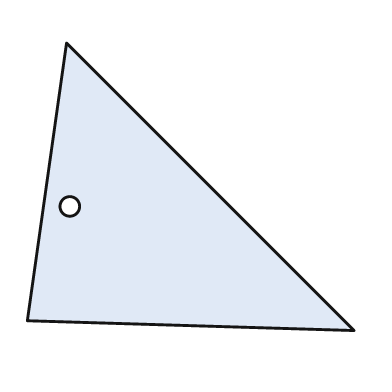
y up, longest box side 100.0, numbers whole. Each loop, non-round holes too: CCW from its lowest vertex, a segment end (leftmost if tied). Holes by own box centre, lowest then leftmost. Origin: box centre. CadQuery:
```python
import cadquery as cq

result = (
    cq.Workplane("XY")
    .moveTo(50.0, -44.0)
    .lineTo(-38.0, 44.0)
    .lineTo(-50.0, -41.0)
    .close()
    .moveTo(-37.0, -6.0)
    .circle(3.0)
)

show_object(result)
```